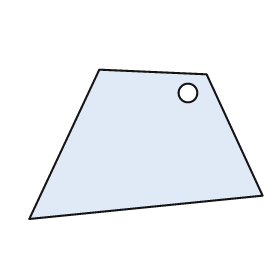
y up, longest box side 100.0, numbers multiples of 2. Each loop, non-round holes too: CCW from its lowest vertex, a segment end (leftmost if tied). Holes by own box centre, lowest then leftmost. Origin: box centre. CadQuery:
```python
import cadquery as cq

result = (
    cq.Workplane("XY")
    .moveTo(-50.0, -32.0)
    .lineTo(50.0, -22.0)
    .lineTo(26.0, 30.0)
    .lineTo(-20.0, 32.0)
    .close()
    .moveTo(18.0, 22.0)
    .circle(4.0)
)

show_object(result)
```